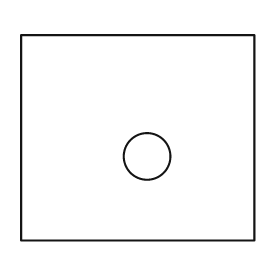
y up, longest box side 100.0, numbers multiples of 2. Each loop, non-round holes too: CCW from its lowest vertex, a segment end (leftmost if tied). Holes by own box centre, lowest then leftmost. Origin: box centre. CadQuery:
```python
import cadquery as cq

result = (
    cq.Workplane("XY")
    .moveTo(-50.0, -44.0)
    .lineTo(50.0, -44.0)
    .lineTo(50.0, 44.0)
    .lineTo(-50.0, 44.0)
    .close()
    .moveTo(4.0, -8.0)
    .circle(10.0)
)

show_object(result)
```